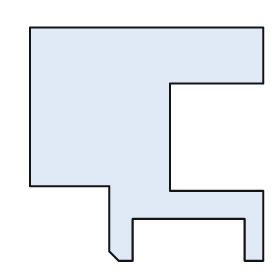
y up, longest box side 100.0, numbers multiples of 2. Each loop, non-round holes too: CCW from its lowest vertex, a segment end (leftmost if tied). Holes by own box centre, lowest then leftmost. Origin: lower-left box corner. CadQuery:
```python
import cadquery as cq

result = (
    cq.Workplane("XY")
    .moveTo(38.0, 0.0)
    .lineTo(44.0, 0.0)
    .lineTo(44.0, 18.0)
    .lineTo(92.0, 18.0)
    .lineTo(92.0, 0.0)
    .lineTo(100.0, 0.0)
    .lineTo(100.0, 30.0)
    .lineTo(60.0, 30.0)
    .lineTo(60.0, 76.0)
    .lineTo(100.0, 76.0)
    .lineTo(100.0, 100.0)
    .lineTo(0.0, 100.0)
    .lineTo(0.0, 32.0)
    .lineTo(34.0, 32.0)
    .lineTo(34.0, 4.0)
    .close()
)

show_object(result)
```